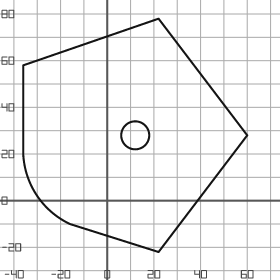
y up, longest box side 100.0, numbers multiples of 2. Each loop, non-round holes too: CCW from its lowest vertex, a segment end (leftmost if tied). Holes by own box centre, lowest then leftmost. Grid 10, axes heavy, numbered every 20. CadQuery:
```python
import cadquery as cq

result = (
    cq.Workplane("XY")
    .moveTo(22.0, -22.0)
    .lineTo(60.0, 28.0)
    .lineTo(22.0, 78.0)
    .lineTo(-36.0, 58.0)
    .lineTo(-36.0, 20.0)
    .threePointArc((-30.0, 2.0), (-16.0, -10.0))
    .close()
    .moveTo(12.0, 28.0)
    .circle(6.0)
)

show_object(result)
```